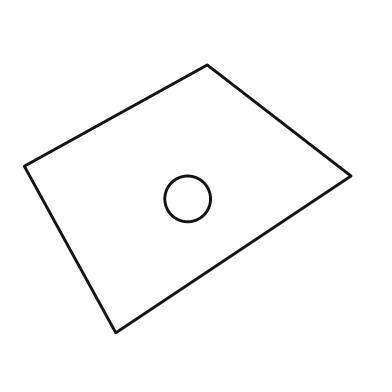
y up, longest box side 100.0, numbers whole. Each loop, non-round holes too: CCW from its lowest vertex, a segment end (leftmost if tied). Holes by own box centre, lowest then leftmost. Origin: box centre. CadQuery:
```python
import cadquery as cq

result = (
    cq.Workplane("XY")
    .moveTo(-22.0, -41.0)
    .lineTo(50.0, 7.0)
    .lineTo(6.0, 41.0)
    .lineTo(-50.0, 10.0)
    .close()
    .moveTo(0.0, 0.0)
    .circle(7.0)
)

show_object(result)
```